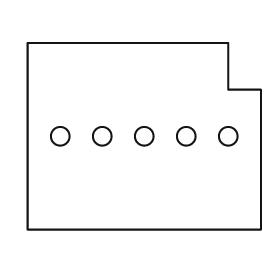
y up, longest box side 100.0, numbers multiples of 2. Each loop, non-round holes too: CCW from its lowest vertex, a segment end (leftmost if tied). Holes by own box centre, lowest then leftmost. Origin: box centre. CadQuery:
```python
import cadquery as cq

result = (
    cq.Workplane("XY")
    .moveTo(-50.0, -40.0)
    .lineTo(50.0, -40.0)
    .lineTo(50.0, 20.0)
    .lineTo(36.0, 20.0)
    .lineTo(36.0, 40.0)
    .lineTo(-50.0, 40.0)
    .close()
    .moveTo(-36.0, 0.0)
    .circle(4.0)
    .moveTo(-18.0, 0.0)
    .circle(4.0)
    .moveTo(0.0, 0.0)
    .circle(4.0)
    .moveTo(18.0, 0.0)
    .circle(4.0)
    .moveTo(36.0, 0.0)
    .circle(4.0)
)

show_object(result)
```